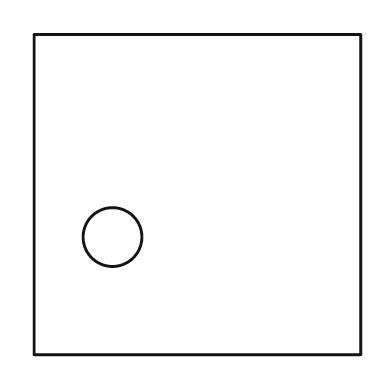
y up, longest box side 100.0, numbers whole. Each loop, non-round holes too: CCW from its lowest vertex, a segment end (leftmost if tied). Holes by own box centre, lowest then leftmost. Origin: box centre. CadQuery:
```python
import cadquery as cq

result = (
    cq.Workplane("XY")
    .moveTo(-50.0, -49.0)
    .lineTo(50.0, -49.0)
    .lineTo(50.0, 49.0)
    .lineTo(-50.0, 49.0)
    .close()
    .moveTo(-26.0, -13.0)
    .circle(9.0)
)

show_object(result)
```